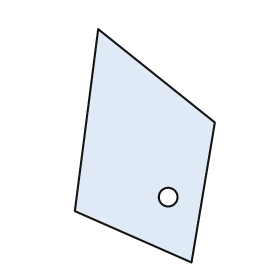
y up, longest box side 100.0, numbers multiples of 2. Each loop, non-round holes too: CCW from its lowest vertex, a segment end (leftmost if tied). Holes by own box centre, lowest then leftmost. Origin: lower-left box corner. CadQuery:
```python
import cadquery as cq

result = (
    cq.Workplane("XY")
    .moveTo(50.0, 0.0)
    .lineTo(60.0, 60.0)
    .lineTo(10.0, 100.0)
    .lineTo(0.0, 22.0)
    .close()
    .moveTo(40.0, 28.0)
    .circle(4.0)
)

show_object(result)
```